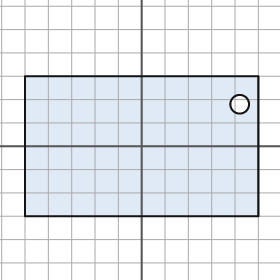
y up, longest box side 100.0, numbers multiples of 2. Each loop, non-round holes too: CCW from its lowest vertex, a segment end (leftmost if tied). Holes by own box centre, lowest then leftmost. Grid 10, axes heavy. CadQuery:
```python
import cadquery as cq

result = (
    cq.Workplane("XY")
    .moveTo(-50.0, -30.0)
    .lineTo(50.0, -30.0)
    .lineTo(50.0, 30.0)
    .lineTo(-50.0, 30.0)
    .close()
    .moveTo(42.0, 18.0)
    .circle(4.0)
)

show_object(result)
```